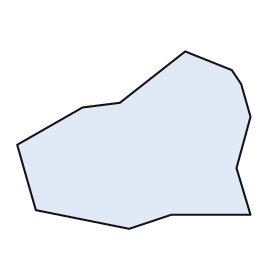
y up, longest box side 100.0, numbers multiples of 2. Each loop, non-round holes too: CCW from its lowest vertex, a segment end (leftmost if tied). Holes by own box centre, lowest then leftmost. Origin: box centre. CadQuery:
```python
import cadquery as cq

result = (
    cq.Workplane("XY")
    .moveTo(-2.0, -38.0)
    .lineTo(16.0, -32.0)
    .lineTo(50.0, -32.0)
    .lineTo(44.0, -12.0)
    .lineTo(50.0, 10.0)
    .lineTo(46.0, 24.0)
    .lineTo(42.0, 30.0)
    .lineTo(22.0, 38.0)
    .lineTo(-6.0, 16.0)
    .lineTo(-22.0, 14.0)
    .lineTo(-50.0, -2.0)
    .lineTo(-42.0, -30.0)
    .close()
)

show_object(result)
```